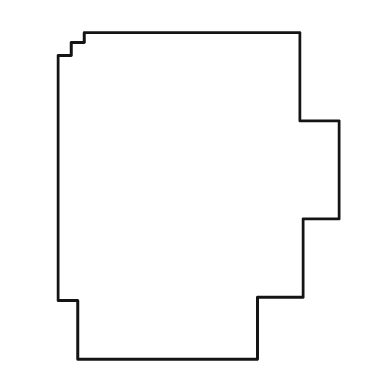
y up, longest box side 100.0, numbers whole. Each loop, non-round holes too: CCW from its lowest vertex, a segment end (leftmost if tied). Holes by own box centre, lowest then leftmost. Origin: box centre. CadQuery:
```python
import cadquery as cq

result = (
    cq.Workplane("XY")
    .moveTo(-37.0, -50.0)
    .lineTo(18.0, -50.0)
    .lineTo(18.0, -31.0)
    .lineTo(32.0, -31.0)
    .lineTo(32.0, -7.0)
    .lineTo(43.0, -7.0)
    .lineTo(43.0, 23.0)
    .lineTo(31.0, 23.0)
    .lineTo(31.0, 50.0)
    .lineTo(-35.0, 50.0)
    .lineTo(-35.0, 47.0)
    .lineTo(-39.0, 47.0)
    .lineTo(-39.0, 43.0)
    .lineTo(-43.0, 43.0)
    .lineTo(-43.0, -32.0)
    .lineTo(-37.0, -32.0)
    .close()
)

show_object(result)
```